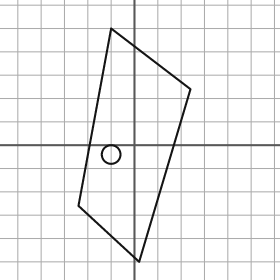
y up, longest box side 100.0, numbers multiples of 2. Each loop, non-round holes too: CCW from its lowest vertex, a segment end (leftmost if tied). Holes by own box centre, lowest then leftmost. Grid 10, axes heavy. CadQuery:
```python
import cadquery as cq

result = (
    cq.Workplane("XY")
    .moveTo(2.0, -50.0)
    .lineTo(24.0, 24.0)
    .lineTo(-10.0, 50.0)
    .lineTo(-24.0, -26.0)
    .close()
    .moveTo(-10.0, -4.0)
    .circle(4.0)
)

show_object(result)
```